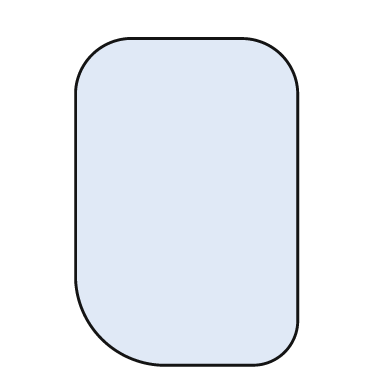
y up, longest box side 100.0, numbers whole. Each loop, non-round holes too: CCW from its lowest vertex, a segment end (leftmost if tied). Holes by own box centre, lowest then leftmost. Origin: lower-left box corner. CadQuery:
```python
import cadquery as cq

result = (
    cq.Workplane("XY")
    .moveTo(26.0, 0.0)
    .lineTo(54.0, 0.0)
    .threePointArc((64.0, 4.0), (68.0, 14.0))
    .lineTo(68.0, 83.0)
    .threePointArc((63.0, 95.0), (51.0, 100.0))
    .lineTo(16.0, 100.0)
    .threePointArc((5.0, 95.0), (0.0, 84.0))
    .lineTo(0.0, 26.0)
    .threePointArc((8.0, 8.0), (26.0, 0.0))
    .close()
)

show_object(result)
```